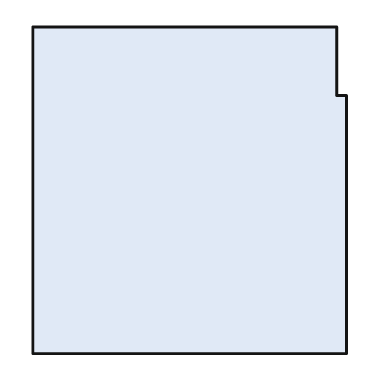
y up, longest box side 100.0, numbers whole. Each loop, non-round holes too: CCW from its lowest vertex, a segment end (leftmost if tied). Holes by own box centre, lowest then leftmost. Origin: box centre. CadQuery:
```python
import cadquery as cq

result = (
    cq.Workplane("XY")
    .moveTo(-48.0, -50.0)
    .lineTo(48.0, -50.0)
    .lineTo(48.0, 29.0)
    .lineTo(45.0, 29.0)
    .lineTo(45.0, 50.0)
    .lineTo(-48.0, 50.0)
    .close()
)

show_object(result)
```